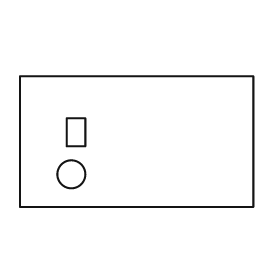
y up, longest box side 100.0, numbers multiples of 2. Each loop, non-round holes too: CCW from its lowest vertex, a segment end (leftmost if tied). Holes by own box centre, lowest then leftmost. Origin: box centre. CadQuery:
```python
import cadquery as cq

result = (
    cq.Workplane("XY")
    .moveTo(-50.0, -28.0)
    .lineTo(50.0, -28.0)
    .lineTo(50.0, 28.0)
    .lineTo(-50.0, 28.0)
    .close()
    .moveTo(-28.0, -14.0)
    .circle(6.0)
    .moveTo(-30.0, -2.0)
    .lineTo(-22.0, -2.0)
    .lineTo(-22.0, 10.0)
    .lineTo(-30.0, 10.0)
    .close()
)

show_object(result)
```